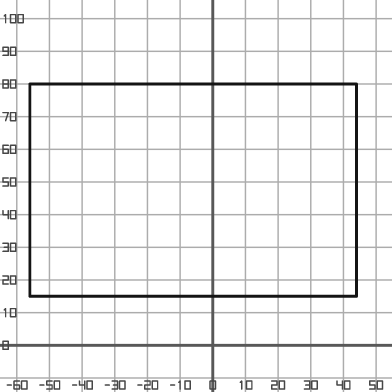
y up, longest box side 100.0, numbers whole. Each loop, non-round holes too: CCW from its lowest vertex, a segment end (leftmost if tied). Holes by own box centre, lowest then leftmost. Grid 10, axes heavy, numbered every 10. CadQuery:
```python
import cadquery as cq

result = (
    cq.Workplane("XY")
    .moveTo(-56.0, 15.0)
    .lineTo(44.0, 15.0)
    .lineTo(44.0, 80.0)
    .lineTo(-56.0, 80.0)
    .close()
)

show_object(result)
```